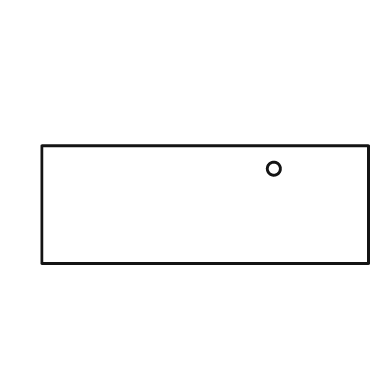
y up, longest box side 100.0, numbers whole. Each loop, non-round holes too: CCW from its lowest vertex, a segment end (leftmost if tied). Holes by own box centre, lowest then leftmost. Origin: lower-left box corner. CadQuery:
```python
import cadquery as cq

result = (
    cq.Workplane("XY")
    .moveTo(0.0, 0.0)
    .lineTo(100.0, 0.0)
    .lineTo(100.0, 36.0)
    .lineTo(0.0, 36.0)
    .close()
    .moveTo(71.0, 29.0)
    .circle(2.0)
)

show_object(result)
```